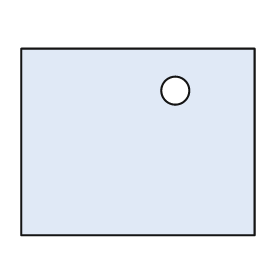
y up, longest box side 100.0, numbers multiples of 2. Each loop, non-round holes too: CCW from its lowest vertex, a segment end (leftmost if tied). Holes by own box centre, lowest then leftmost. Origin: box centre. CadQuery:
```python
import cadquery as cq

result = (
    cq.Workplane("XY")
    .moveTo(-50.0, -40.0)
    .lineTo(50.0, -40.0)
    .lineTo(50.0, 40.0)
    .lineTo(-50.0, 40.0)
    .close()
    .moveTo(16.0, 22.0)
    .circle(6.0)
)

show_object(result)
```